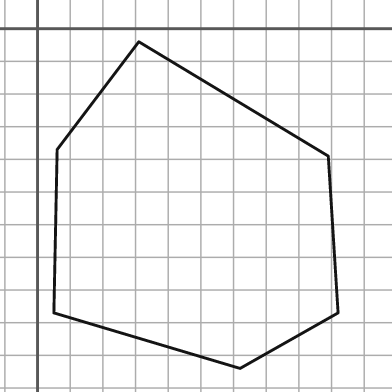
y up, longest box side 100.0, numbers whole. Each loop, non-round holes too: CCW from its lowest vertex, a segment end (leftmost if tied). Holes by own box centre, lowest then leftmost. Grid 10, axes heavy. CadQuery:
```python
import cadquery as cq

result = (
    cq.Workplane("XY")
    .moveTo(62.0, -104.0)
    .lineTo(92.0, -87.0)
    .lineTo(89.0, -39.0)
    .lineTo(31.0, -4.0)
    .lineTo(6.0, -37.0)
    .lineTo(5.0, -87.0)
    .close()
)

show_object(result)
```